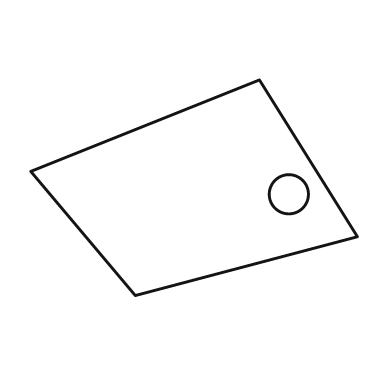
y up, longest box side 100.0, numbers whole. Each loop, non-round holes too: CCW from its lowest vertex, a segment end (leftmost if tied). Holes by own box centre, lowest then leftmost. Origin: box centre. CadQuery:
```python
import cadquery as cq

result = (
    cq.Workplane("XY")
    .moveTo(-18.0, -33.0)
    .lineTo(50.0, -15.0)
    .lineTo(20.0, 33.0)
    .lineTo(-50.0, 5.0)
    .close()
    .moveTo(29.0, -2.0)
    .circle(6.0)
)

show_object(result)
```